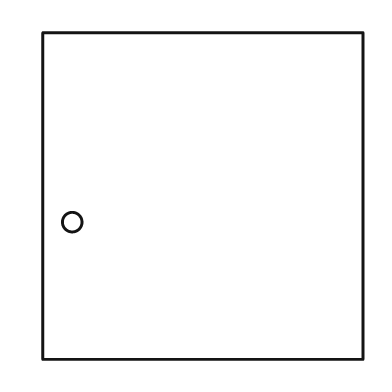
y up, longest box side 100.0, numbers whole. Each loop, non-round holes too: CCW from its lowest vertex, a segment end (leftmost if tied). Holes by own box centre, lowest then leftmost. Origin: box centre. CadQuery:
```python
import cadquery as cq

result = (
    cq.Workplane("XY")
    .moveTo(-49.0, -50.0)
    .lineTo(49.0, -50.0)
    .lineTo(49.0, 50.0)
    .lineTo(-49.0, 50.0)
    .close()
    .moveTo(-40.0, -8.0)
    .circle(3.0)
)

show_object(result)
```